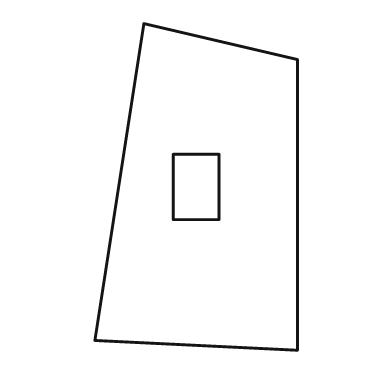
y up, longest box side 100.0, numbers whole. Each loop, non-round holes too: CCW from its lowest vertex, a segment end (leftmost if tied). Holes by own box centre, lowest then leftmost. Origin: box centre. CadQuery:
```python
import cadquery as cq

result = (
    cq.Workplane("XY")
    .moveTo(31.0, -50.0)
    .lineTo(31.0, 39.0)
    .lineTo(-16.0, 50.0)
    .lineTo(-31.0, -47.0)
    .close()
    .moveTo(-7.0, -10.0)
    .lineTo(7.0, -10.0)
    .lineTo(7.0, 10.0)
    .lineTo(-7.0, 10.0)
    .close()
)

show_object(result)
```